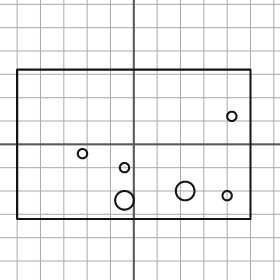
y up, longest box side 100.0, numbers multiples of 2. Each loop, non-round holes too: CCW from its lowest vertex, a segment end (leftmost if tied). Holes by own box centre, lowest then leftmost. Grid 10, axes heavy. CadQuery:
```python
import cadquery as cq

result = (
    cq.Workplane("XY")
    .moveTo(-50.0, -32.0)
    .lineTo(50.0, -32.0)
    .lineTo(50.0, 32.0)
    .lineTo(-50.0, 32.0)
    .close()
    .moveTo(-4.0, -24.0)
    .circle(4.0)
    .moveTo(40.0, -22.0)
    .circle(2.0)
    .moveTo(22.0, -20.0)
    .circle(4.0)
    .moveTo(-4.0, -10.0)
    .circle(2.0)
    .moveTo(-22.0, -4.0)
    .circle(2.0)
    .moveTo(42.0, 12.0)
    .circle(2.0)
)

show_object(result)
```